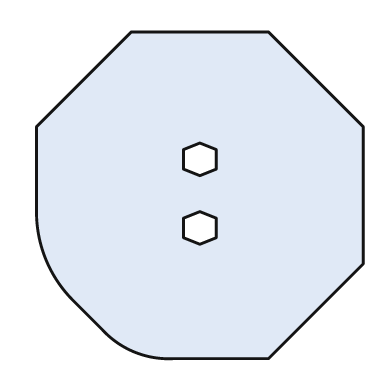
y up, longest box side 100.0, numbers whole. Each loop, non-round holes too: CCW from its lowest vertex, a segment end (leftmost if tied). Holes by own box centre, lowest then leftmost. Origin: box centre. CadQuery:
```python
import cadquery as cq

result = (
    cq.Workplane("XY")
    .moveTo(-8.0, -50.0)
    .lineTo(21.0, -50.0)
    .lineTo(50.0, -21.0)
    .lineTo(50.0, 21.0)
    .lineTo(21.0, 50.0)
    .lineTo(-21.0, 50.0)
    .lineTo(-50.0, 21.0)
    .lineTo(-50.0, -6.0)
    .threePointArc((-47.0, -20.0), (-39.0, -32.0))
    .lineTo(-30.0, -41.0)
    .threePointArc((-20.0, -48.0), (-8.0, -50.0))
    .close()
    .moveTo(0.0, -15.0)
    .lineTo(5.0, -13.0)
    .lineTo(5.0, -7.0)
    .lineTo(0.0, -5.0)
    .lineTo(-5.0, -7.0)
    .lineTo(-5.0, -13.0)
    .close()
    .moveTo(0.0, 6.0)
    .lineTo(5.0, 8.0)
    .lineTo(5.0, 14.0)
    .lineTo(0.0, 16.0)
    .lineTo(-5.0, 14.0)
    .lineTo(-5.0, 8.0)
    .close()
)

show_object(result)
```